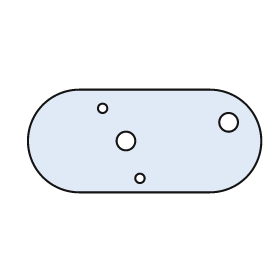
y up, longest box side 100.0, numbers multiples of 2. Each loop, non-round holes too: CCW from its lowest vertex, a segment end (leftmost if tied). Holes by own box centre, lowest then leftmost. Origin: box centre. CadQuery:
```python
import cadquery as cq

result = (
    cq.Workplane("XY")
    .moveTo(-28.0, -22.0)
    .lineTo(28.0, -22.0)
    .threePointArc((50.0, 0.0), (28.0, 22.0))
    .lineTo(-28.0, 22.0)
    .threePointArc((-50.0, 0.0), (-28.0, -22.0))
    .close()
    .moveTo(-2.0, -16.0)
    .circle(2.0)
    .moveTo(-8.0, 0.0)
    .circle(4.0)
    .moveTo(36.0, 8.0)
    .circle(4.0)
    .moveTo(-18.0, 14.0)
    .circle(2.0)
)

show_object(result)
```